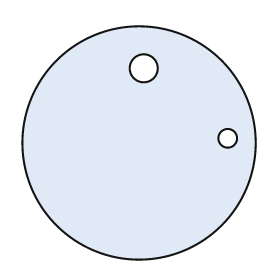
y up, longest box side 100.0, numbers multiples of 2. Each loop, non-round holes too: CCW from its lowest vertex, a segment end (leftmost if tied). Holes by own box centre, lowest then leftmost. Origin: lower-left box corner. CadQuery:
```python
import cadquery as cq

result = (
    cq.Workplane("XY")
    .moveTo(50.0, 50.0)
    .circle(50.0)
    .moveTo(88.0, 52.0)
    .circle(4.0)
    .moveTo(52.0, 82.0)
    .circle(6.0)
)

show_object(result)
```